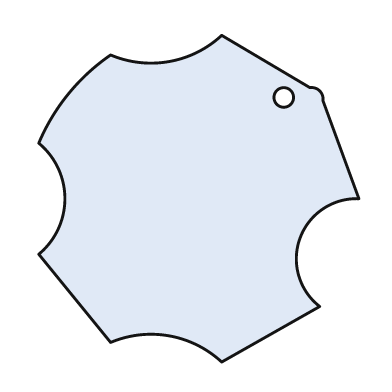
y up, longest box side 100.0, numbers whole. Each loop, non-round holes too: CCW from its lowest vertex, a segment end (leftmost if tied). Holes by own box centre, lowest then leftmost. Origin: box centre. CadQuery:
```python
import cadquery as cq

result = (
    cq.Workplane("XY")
    .moveTo(7.0, -50.0)
    .lineTo(37.0, -33.0)
    .threePointArc((31.0, -12.0), (49.0, 0.0))
    .lineTo(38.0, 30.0)
    .threePointArc((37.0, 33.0), (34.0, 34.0))
    .lineTo(7.0, 50.0)
    .threePointArc((-9.0, 42.0), (-27.0, 44.0))
    .threePointArc((-40.0, 32.0), (-49.0, 17.0))
    .threePointArc((-41.0, 0.0), (-49.0, -17.0))
    .lineTo(-27.0, -44.0)
    .threePointArc((-9.0, -42.0), (7.0, -50.0))
    .close()
    .moveTo(26.0, 31.0)
    .circle(3.0)
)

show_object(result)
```